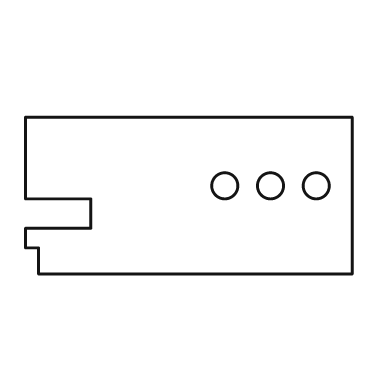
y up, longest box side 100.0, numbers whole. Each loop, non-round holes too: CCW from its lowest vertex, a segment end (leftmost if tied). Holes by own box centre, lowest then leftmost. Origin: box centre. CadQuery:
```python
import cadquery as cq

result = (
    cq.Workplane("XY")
    .moveTo(-46.0, -24.0)
    .lineTo(50.0, -24.0)
    .lineTo(50.0, 24.0)
    .lineTo(-50.0, 24.0)
    .lineTo(-50.0, -1.0)
    .lineTo(-30.0, -1.0)
    .lineTo(-30.0, -10.0)
    .lineTo(-50.0, -10.0)
    .lineTo(-50.0, -16.0)
    .lineTo(-46.0, -16.0)
    .close()
    .moveTo(11.0, 3.0)
    .circle(4.0)
    .moveTo(25.0, 3.0)
    .circle(4.0)
    .moveTo(39.0, 3.0)
    .circle(4.0)
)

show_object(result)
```